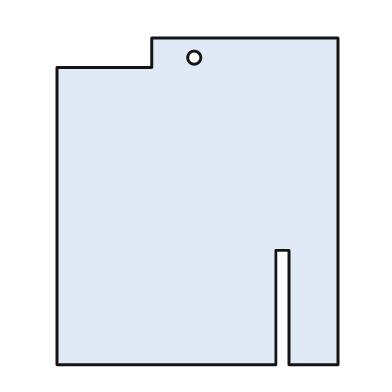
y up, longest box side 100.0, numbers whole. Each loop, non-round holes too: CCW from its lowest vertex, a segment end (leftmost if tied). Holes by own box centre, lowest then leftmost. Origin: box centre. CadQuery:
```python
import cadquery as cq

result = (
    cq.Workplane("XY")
    .moveTo(-43.0, -50.0)
    .lineTo(24.0, -50.0)
    .lineTo(24.0, -15.0)
    .lineTo(28.0, -15.0)
    .lineTo(28.0, -50.0)
    .lineTo(43.0, -50.0)
    .lineTo(43.0, 50.0)
    .lineTo(-14.0, 50.0)
    .lineTo(-14.0, 41.0)
    .lineTo(-43.0, 41.0)
    .close()
    .moveTo(-1.0, 44.0)
    .circle(2.0)
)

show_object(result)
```